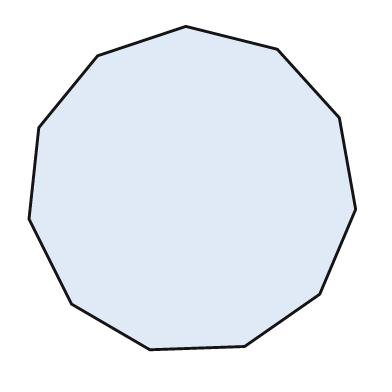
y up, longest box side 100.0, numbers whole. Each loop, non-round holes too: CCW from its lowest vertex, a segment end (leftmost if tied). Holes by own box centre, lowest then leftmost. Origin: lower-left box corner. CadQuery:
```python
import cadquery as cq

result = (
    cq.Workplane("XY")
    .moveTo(37.0, 0.0)
    .lineTo(66.0, 1.0)
    .lineTo(89.0, 17.0)
    .lineTo(100.0, 43.0)
    .lineTo(95.0, 71.0)
    .lineTo(76.0, 92.0)
    .lineTo(48.0, 99.0)
    .lineTo(21.0, 90.0)
    .lineTo(3.0, 68.0)
    .lineTo(0.0, 40.0)
    .lineTo(13.0, 14.0)
    .close()
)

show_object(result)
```